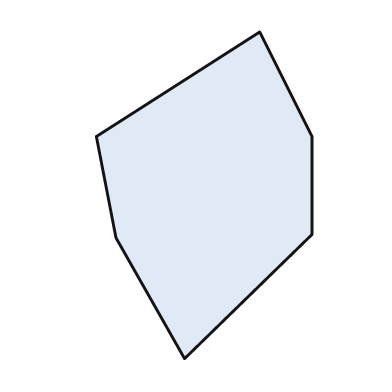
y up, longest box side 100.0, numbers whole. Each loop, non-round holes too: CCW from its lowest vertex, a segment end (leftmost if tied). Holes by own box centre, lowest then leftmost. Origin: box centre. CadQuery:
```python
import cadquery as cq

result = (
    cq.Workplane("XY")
    .moveTo(-6.0, -50.0)
    .lineTo(33.0, -12.0)
    .lineTo(33.0, 18.0)
    .lineTo(17.0, 50.0)
    .lineTo(-33.0, 18.0)
    .lineTo(-27.0, -13.0)
    .close()
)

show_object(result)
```